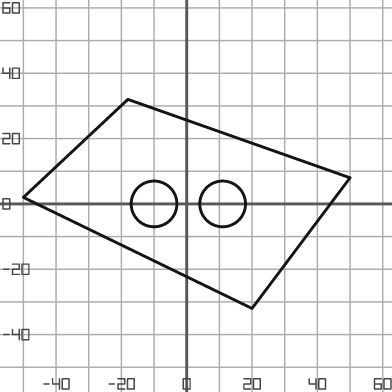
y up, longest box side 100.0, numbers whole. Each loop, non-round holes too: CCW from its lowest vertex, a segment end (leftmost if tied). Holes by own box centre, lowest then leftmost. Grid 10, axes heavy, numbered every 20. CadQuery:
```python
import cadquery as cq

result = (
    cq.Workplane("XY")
    .moveTo(20.0, -32.0)
    .lineTo(50.0, 8.0)
    .lineTo(-18.0, 32.0)
    .lineTo(-50.0, 2.0)
    .close()
    .moveTo(-10.0, 0.0)
    .circle(7.0)
    .moveTo(11.0, 0.0)
    .circle(7.0)
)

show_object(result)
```